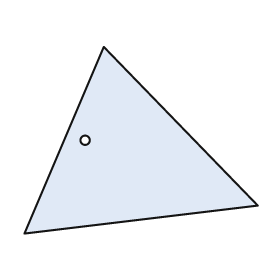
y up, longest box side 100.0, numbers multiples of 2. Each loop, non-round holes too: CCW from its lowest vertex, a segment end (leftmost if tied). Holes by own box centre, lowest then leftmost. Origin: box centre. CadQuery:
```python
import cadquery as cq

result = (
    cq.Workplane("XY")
    .moveTo(-50.0, -40.0)
    .lineTo(50.0, -28.0)
    .lineTo(-16.0, 40.0)
    .close()
    .moveTo(-24.0, 0.0)
    .circle(2.0)
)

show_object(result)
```